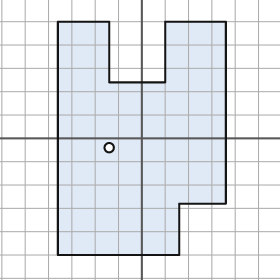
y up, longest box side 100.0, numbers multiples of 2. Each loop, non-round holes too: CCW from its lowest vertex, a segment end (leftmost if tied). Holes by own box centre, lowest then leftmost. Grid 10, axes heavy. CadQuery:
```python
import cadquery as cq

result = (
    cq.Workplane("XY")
    .moveTo(-36.0, -50.0)
    .lineTo(16.0, -50.0)
    .lineTo(16.0, -28.0)
    .lineTo(36.0, -28.0)
    .lineTo(36.0, 50.0)
    .lineTo(10.0, 50.0)
    .lineTo(10.0, 24.0)
    .lineTo(-14.0, 24.0)
    .lineTo(-14.0, 50.0)
    .lineTo(-36.0, 50.0)
    .close()
    .moveTo(-14.0, -4.0)
    .circle(2.0)
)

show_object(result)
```